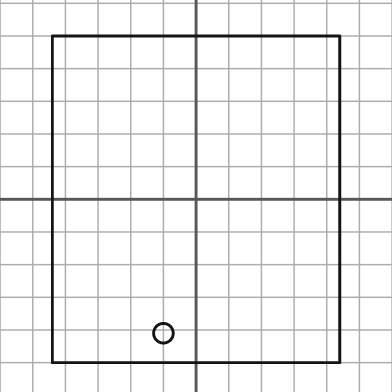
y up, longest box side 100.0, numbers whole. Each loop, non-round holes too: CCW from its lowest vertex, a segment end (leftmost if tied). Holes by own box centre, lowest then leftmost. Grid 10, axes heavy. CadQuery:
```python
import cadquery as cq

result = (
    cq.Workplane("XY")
    .moveTo(-44.0, -50.0)
    .lineTo(44.0, -50.0)
    .lineTo(44.0, 50.0)
    .lineTo(-44.0, 50.0)
    .close()
    .moveTo(-10.0, -41.0)
    .circle(3.0)
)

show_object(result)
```